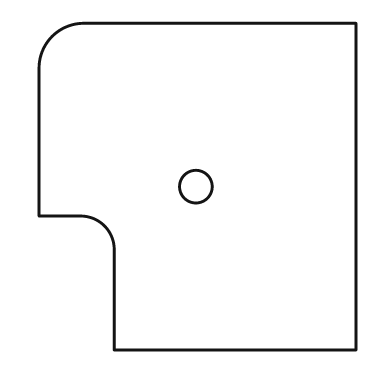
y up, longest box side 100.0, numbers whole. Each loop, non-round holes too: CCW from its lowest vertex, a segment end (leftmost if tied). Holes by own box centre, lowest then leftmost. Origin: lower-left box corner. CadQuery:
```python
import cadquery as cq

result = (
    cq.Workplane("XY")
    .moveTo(23.0, 0.0)
    .lineTo(97.0, 0.0)
    .lineTo(97.0, 100.0)
    .lineTo(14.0, 100.0)
    .threePointArc((4.0, 96.0), (0.0, 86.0))
    .lineTo(0.0, 41.0)
    .lineTo(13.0, 41.0)
    .threePointArc((20.0, 38.0), (23.0, 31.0))
    .close()
    .moveTo(48.0, 50.0)
    .circle(5.0)
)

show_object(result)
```